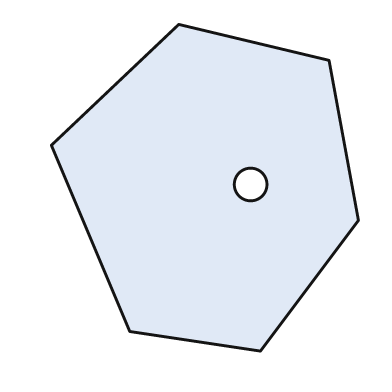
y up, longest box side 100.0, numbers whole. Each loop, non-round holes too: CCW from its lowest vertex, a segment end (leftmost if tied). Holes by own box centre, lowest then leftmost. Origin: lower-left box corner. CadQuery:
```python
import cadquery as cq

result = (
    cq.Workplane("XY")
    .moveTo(64.0, 0.0)
    .lineTo(94.0, 40.0)
    .lineTo(85.0, 89.0)
    .lineTo(39.0, 100.0)
    .lineTo(0.0, 63.0)
    .lineTo(24.0, 6.0)
    .close()
    .moveTo(61.0, 51.0)
    .circle(5.0)
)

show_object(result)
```